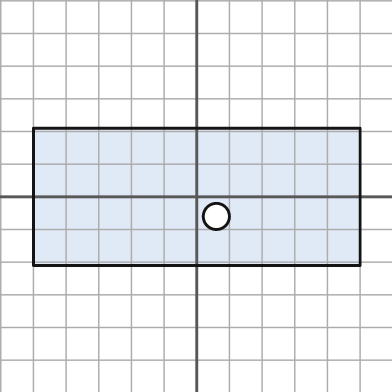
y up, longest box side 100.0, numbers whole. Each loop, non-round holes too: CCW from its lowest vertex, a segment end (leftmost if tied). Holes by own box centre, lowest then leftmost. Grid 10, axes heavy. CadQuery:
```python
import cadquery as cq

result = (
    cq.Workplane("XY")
    .moveTo(-50.0, -21.0)
    .lineTo(50.0, -21.0)
    .lineTo(50.0, 21.0)
    .lineTo(-50.0, 21.0)
    .close()
    .moveTo(6.0, -6.0)
    .circle(4.0)
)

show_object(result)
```